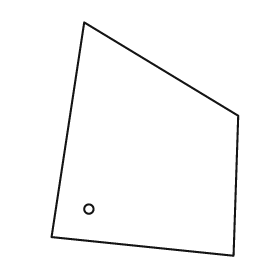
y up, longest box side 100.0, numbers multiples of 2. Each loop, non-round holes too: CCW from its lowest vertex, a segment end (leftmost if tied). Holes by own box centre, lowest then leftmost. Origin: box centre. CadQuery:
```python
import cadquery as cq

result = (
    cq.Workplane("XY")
    .moveTo(38.0, -50.0)
    .lineTo(40.0, 10.0)
    .lineTo(-26.0, 50.0)
    .lineTo(-40.0, -42.0)
    .close()
    .moveTo(-24.0, -30.0)
    .circle(2.0)
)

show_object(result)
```